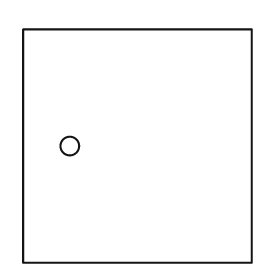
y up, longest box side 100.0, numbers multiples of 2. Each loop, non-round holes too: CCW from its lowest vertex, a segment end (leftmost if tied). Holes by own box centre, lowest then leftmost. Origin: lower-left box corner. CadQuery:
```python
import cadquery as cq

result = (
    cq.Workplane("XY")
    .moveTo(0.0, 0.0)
    .lineTo(98.0, 0.0)
    .lineTo(98.0, 100.0)
    .lineTo(0.0, 100.0)
    .close()
    .moveTo(20.0, 50.0)
    .circle(4.0)
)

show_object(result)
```